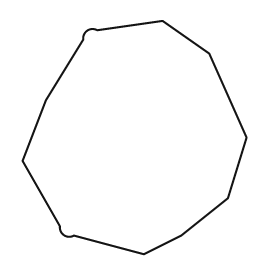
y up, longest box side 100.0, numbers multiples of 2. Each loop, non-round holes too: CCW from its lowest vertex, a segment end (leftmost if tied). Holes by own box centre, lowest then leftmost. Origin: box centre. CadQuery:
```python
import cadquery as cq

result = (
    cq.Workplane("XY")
    .moveTo(4.0, -50.0)
    .lineTo(20.0, -42.0)
    .lineTo(40.0, -26.0)
    .lineTo(48.0, 0.0)
    .lineTo(32.0, 36.0)
    .lineTo(12.0, 50.0)
    .lineTo(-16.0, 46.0)
    .threePointArc((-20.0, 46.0), (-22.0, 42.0))
    .lineTo(-38.0, 16.0)
    .lineTo(-48.0, -10.0)
    .lineTo(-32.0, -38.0)
    .threePointArc((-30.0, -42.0), (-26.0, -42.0))
    .close()
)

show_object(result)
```